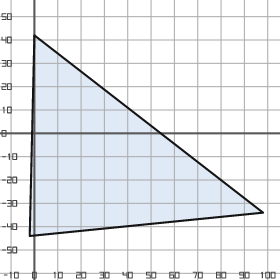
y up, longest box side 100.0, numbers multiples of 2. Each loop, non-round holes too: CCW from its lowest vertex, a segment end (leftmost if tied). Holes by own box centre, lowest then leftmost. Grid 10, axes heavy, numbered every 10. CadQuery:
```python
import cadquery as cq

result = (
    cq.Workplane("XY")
    .moveTo(-2.0, -44.0)
    .lineTo(98.0, -34.0)
    .lineTo(0.0, 42.0)
    .close()
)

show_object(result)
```